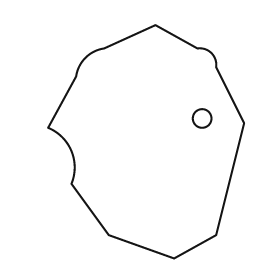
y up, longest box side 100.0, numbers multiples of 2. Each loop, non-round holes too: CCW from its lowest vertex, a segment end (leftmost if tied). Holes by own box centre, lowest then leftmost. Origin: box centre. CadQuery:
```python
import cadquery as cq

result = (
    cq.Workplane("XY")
    .moveTo(12.0, -50.0)
    .lineTo(30.0, -40.0)
    .lineTo(42.0, 8.0)
    .lineTo(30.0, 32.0)
    .threePointArc((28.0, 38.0), (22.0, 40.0))
    .lineTo(4.0, 50.0)
    .lineTo(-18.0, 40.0)
    .threePointArc((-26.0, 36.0), (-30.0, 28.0))
    .lineTo(-42.0, 6.0)
    .threePointArc((-32.0, -4.0), (-32.0, -18.0))
    .lineTo(-16.0, -40.0)
    .close()
    .moveTo(24.0, 10.0)
    .circle(4.0)
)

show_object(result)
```